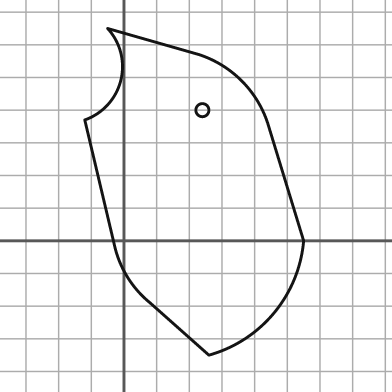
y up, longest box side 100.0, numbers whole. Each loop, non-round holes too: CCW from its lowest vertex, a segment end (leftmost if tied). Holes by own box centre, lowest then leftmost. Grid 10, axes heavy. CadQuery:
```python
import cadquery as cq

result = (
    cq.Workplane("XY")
    .moveTo(26.0, -35.0)
    .threePointArc((46.0, -22.0), (55.0, 0.0))
    .lineTo(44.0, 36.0)
    .threePointArc((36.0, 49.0), (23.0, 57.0))
    .lineTo(-5.0, 65.0)
    .threePointArc((-1.0, 49.0), (-12.0, 37.0))
    .lineTo(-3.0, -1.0)
    .threePointArc((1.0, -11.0), (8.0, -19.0))
    .close()
    .moveTo(24.0, 40.0)
    .circle(2.0)
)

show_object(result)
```